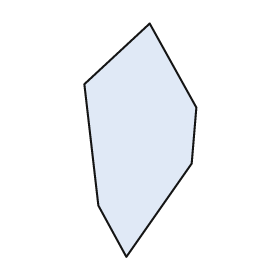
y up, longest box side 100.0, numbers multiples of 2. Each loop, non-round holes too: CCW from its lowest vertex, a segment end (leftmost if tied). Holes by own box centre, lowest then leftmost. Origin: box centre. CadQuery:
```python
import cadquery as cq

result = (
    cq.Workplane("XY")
    .moveTo(-6.0, -50.0)
    .lineTo(22.0, -10.0)
    .lineTo(24.0, 14.0)
    .lineTo(4.0, 50.0)
    .lineTo(-24.0, 24.0)
    .lineTo(-18.0, -28.0)
    .close()
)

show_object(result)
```